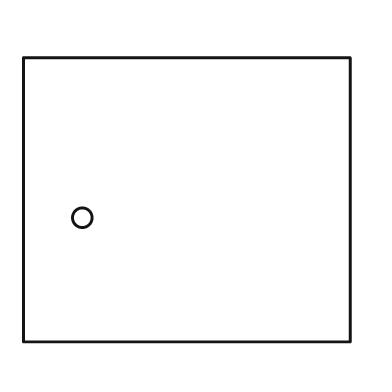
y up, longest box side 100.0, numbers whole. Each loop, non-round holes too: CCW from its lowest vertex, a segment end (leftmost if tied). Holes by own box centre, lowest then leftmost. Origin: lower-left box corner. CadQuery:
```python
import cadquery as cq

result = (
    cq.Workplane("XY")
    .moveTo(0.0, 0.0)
    .lineTo(100.0, 0.0)
    .lineTo(100.0, 87.0)
    .lineTo(0.0, 87.0)
    .close()
    .moveTo(18.0, 38.0)
    .circle(3.0)
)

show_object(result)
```